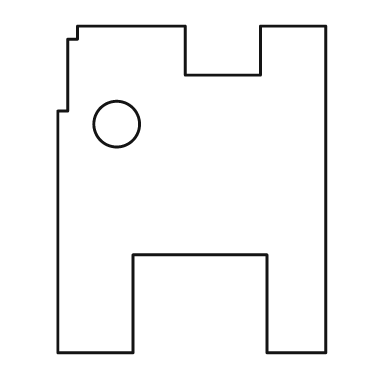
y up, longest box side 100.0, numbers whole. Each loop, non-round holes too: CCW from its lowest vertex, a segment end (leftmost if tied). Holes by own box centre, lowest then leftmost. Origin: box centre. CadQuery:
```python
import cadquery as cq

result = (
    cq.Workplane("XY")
    .moveTo(-41.0, -50.0)
    .lineTo(-18.0, -50.0)
    .lineTo(-18.0, -20.0)
    .lineTo(23.0, -20.0)
    .lineTo(23.0, -50.0)
    .lineTo(41.0, -50.0)
    .lineTo(41.0, 50.0)
    .lineTo(21.0, 50.0)
    .lineTo(21.0, 35.0)
    .lineTo(-2.0, 35.0)
    .lineTo(-2.0, 50.0)
    .lineTo(-35.0, 50.0)
    .lineTo(-35.0, 46.0)
    .lineTo(-38.0, 46.0)
    .lineTo(-38.0, 24.0)
    .lineTo(-41.0, 24.0)
    .close()
    .moveTo(-23.0, 20.0)
    .circle(7.0)
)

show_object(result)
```